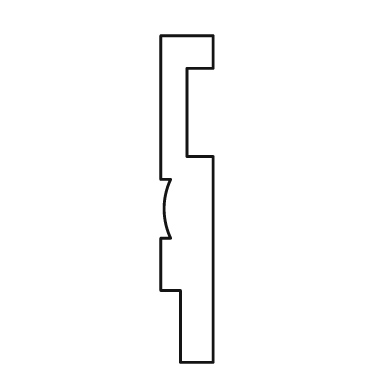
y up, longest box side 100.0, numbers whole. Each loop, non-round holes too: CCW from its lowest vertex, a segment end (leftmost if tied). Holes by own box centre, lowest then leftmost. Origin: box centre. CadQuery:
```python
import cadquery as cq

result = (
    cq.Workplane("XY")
    .moveTo(-2.0, -50.0)
    .lineTo(8.0, -50.0)
    .lineTo(8.0, 13.0)
    .lineTo(0.0, 13.0)
    .lineTo(0.0, 40.0)
    .lineTo(8.0, 40.0)
    .lineTo(8.0, 50.0)
    .lineTo(-8.0, 50.0)
    .lineTo(-8.0, 6.0)
    .lineTo(-5.0, 6.0)
    .threePointArc((-7.0, -3.0), (-5.0, -12.0))
    .lineTo(-8.0, -12.0)
    .lineTo(-8.0, -28.0)
    .lineTo(-2.0, -28.0)
    .close()
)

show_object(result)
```